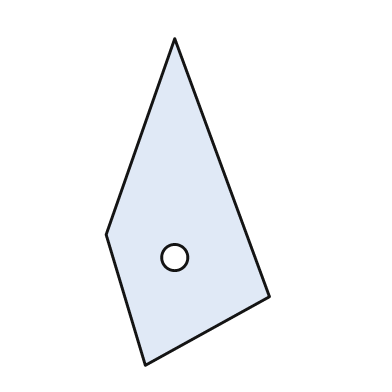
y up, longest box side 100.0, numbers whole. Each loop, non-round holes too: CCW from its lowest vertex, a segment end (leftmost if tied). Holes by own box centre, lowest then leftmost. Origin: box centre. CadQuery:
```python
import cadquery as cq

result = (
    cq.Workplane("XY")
    .moveTo(-13.0, -50.0)
    .lineTo(25.0, -29.0)
    .lineTo(-4.0, 50.0)
    .lineTo(-25.0, -10.0)
    .close()
    .moveTo(-4.0, -17.0)
    .circle(4.0)
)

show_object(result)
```